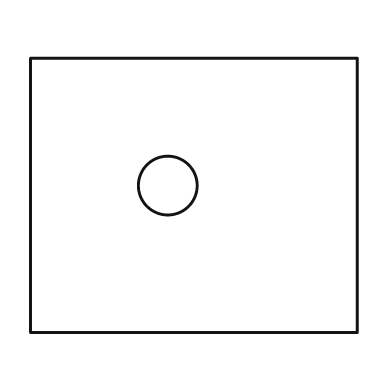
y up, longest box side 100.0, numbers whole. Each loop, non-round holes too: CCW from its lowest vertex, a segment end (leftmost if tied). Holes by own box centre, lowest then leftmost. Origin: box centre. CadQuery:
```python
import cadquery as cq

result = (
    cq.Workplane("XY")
    .moveTo(-50.0, -42.0)
    .lineTo(50.0, -42.0)
    .lineTo(50.0, 42.0)
    .lineTo(-50.0, 42.0)
    .close()
    .moveTo(-8.0, 3.0)
    .circle(9.0)
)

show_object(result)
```